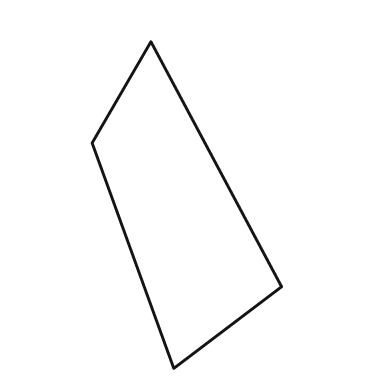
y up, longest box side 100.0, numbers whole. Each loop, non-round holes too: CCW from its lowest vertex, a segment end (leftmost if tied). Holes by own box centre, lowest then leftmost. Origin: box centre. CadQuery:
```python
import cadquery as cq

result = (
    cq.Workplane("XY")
    .moveTo(-4.0, -50.0)
    .lineTo(29.0, -25.0)
    .lineTo(-11.0, 50.0)
    .lineTo(-29.0, 19.0)
    .close()
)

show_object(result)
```